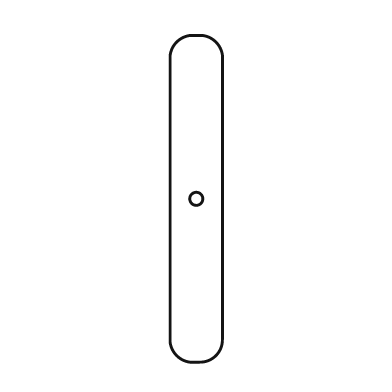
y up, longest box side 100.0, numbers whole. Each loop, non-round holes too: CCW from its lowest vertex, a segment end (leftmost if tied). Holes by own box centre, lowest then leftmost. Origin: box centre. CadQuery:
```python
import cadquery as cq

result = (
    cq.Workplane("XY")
    .moveTo(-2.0, -50.0)
    .lineTo(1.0, -50.0)
    .threePointArc((6.0, -48.0), (8.0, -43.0))
    .lineTo(8.0, 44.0)
    .threePointArc((6.0, 48.0), (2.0, 50.0))
    .lineTo(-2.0, 50.0)
    .threePointArc((-6.0, 48.0), (-8.0, 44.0))
    .lineTo(-8.0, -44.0)
    .threePointArc((-6.0, -48.0), (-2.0, -50.0))
    .close()
    .moveTo(0.0, 0.0)
    .circle(2.0)
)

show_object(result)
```